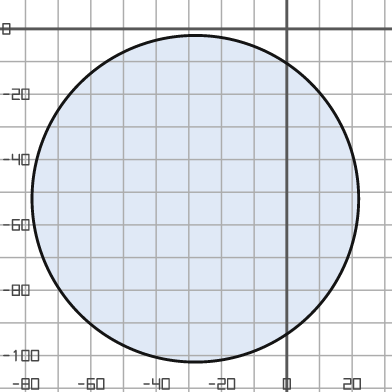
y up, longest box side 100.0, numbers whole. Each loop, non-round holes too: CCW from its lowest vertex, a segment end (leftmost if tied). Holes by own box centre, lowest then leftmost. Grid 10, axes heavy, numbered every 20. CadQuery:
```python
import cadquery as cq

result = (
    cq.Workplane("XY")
    .moveTo(-28.0, -52.0)
    .circle(50.0)
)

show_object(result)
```